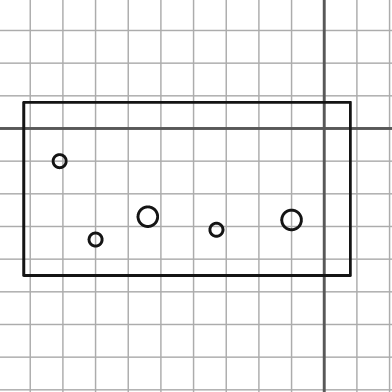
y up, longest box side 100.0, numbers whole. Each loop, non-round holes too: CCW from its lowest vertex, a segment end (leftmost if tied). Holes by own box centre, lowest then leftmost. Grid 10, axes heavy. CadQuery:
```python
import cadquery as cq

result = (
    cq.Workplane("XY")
    .moveTo(-92.0, -45.0)
    .lineTo(8.0, -45.0)
    .lineTo(8.0, 8.0)
    .lineTo(-92.0, 8.0)
    .close()
    .moveTo(-70.0, -34.0)
    .circle(2.0)
    .moveTo(-33.0, -31.0)
    .circle(2.0)
    .moveTo(-10.0, -28.0)
    .circle(3.0)
    .moveTo(-54.0, -27.0)
    .circle(3.0)
    .moveTo(-81.0, -10.0)
    .circle(2.0)
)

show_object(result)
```